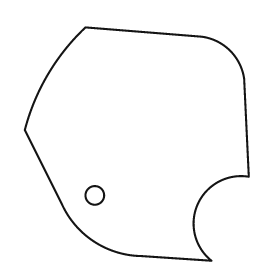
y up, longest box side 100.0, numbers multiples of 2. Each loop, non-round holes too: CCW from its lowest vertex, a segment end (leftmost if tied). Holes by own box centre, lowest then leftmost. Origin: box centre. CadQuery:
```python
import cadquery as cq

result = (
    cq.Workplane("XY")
    .moveTo(32.0, -50.0)
    .threePointArc((26.0, -26.0), (48.0, -14.0))
    .lineTo(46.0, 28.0)
    .threePointArc((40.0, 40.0), (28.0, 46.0))
    .lineTo(-22.0, 50.0)
    .threePointArc((-38.0, 30.0), (-48.0, 6.0))
    .lineTo(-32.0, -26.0)
    .threePointArc((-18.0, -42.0), (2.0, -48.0))
    .close()
    .moveTo(-18.0, -22.0)
    .circle(4.0)
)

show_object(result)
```